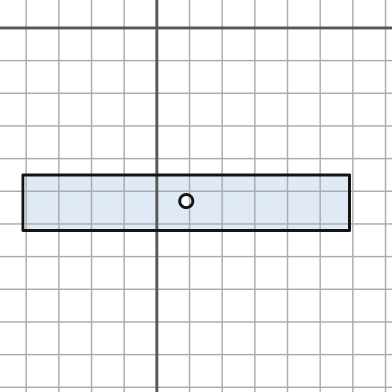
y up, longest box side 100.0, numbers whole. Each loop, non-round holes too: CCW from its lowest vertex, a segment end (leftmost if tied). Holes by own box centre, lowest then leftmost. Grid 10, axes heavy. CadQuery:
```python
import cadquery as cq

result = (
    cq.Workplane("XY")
    .moveTo(-41.0, -62.0)
    .lineTo(59.0, -62.0)
    .lineTo(59.0, -45.0)
    .lineTo(-41.0, -45.0)
    .close()
    .moveTo(9.0, -53.0)
    .circle(2.0)
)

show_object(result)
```